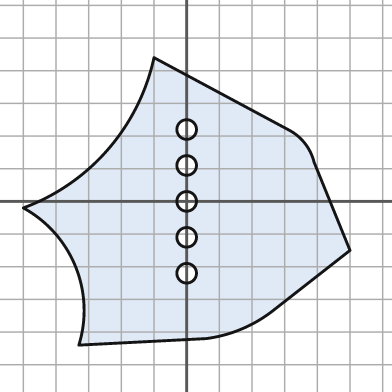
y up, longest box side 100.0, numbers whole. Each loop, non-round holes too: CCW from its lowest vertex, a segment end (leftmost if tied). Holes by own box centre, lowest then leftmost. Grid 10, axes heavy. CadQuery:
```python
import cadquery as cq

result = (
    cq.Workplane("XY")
    .moveTo(-33.0, -44.0)
    .lineTo(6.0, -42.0)
    .threePointArc((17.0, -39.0), (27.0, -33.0))
    .lineTo(50.0, -15.0)
    .lineTo(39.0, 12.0)
    .threePointArc((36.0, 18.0), (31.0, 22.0))
    .lineTo(-10.0, 44.0)
    .threePointArc((-24.0, 16.0), (-50.0, -2.0))
    .threePointArc((-34.0, -20.0), (-33.0, -44.0))
    .close()
    .moveTo(0.0, -22.0)
    .circle(3.0)
    .moveTo(0.0, -11.0)
    .circle(3.0)
    .moveTo(0.0, 0.0)
    .circle(3.0)
    .moveTo(0.0, 11.0)
    .circle(3.0)
    .moveTo(0.0, 22.0)
    .circle(3.0)
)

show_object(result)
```